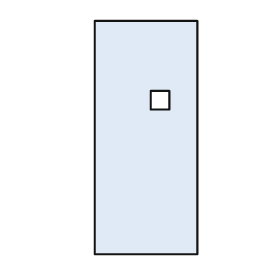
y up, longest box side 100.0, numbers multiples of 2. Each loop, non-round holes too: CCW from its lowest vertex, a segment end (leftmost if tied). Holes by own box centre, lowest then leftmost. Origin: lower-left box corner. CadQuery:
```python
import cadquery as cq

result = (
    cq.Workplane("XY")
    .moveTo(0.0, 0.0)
    .lineTo(44.0, 0.0)
    .lineTo(44.0, 100.0)
    .lineTo(0.0, 100.0)
    .close()
    .moveTo(24.0, 62.0)
    .lineTo(32.0, 62.0)
    .lineTo(32.0, 70.0)
    .lineTo(24.0, 70.0)
    .close()
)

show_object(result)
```